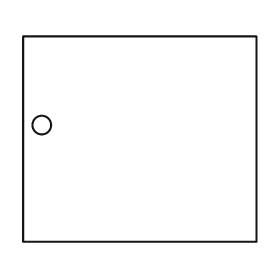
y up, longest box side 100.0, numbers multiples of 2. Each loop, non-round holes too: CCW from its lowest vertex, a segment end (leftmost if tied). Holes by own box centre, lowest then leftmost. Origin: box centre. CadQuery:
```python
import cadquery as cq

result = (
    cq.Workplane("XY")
    .moveTo(-50.0, -44.0)
    .lineTo(50.0, -44.0)
    .lineTo(50.0, 44.0)
    .lineTo(-50.0, 44.0)
    .close()
    .moveTo(-42.0, 6.0)
    .circle(4.0)
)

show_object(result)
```